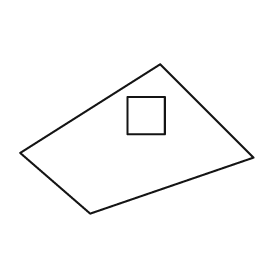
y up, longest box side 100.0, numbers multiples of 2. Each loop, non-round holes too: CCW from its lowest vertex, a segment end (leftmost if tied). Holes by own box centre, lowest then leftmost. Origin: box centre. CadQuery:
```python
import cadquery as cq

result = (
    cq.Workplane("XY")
    .moveTo(-20.0, -32.0)
    .lineTo(50.0, -8.0)
    .lineTo(10.0, 32.0)
    .lineTo(-50.0, -6.0)
    .close()
    .moveTo(-4.0, 2.0)
    .lineTo(12.0, 2.0)
    .lineTo(12.0, 18.0)
    .lineTo(-4.0, 18.0)
    .close()
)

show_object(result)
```